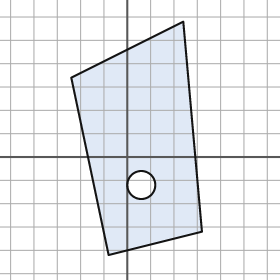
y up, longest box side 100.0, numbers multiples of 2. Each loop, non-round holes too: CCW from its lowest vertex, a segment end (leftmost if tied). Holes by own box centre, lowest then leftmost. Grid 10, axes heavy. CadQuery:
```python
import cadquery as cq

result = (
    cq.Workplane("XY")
    .moveTo(-8.0, -42.0)
    .lineTo(32.0, -32.0)
    .lineTo(24.0, 58.0)
    .lineTo(-24.0, 34.0)
    .close()
    .moveTo(6.0, -12.0)
    .circle(6.0)
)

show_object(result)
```